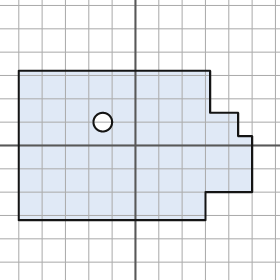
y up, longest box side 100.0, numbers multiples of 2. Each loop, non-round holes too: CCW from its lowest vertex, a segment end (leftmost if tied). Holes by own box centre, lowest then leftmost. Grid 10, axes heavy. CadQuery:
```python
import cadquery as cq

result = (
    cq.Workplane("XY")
    .moveTo(-50.0, -32.0)
    .lineTo(30.0, -32.0)
    .lineTo(30.0, -20.0)
    .lineTo(50.0, -20.0)
    .lineTo(50.0, 4.0)
    .lineTo(44.0, 4.0)
    .lineTo(44.0, 14.0)
    .lineTo(32.0, 14.0)
    .lineTo(32.0, 32.0)
    .lineTo(-50.0, 32.0)
    .close()
    .moveTo(-14.0, 10.0)
    .circle(4.0)
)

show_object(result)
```